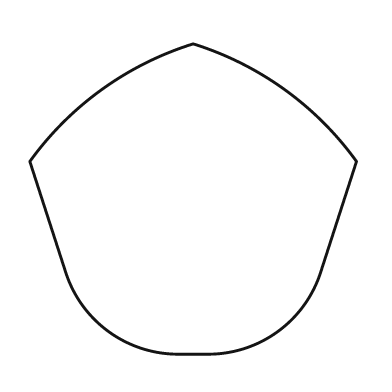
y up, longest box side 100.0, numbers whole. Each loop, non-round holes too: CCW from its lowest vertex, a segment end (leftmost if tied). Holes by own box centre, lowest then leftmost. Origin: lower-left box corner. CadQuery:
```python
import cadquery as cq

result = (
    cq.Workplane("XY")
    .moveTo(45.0, 0.0)
    .lineTo(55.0, 0.0)
    .threePointArc((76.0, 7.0), (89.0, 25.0))
    .lineTo(100.0, 59.0)
    .threePointArc((78.0, 81.0), (50.0, 95.0))
    .threePointArc((22.0, 81.0), (0.0, 59.0))
    .lineTo(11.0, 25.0)
    .threePointArc((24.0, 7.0), (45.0, 0.0))
    .close()
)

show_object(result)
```